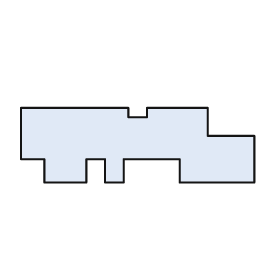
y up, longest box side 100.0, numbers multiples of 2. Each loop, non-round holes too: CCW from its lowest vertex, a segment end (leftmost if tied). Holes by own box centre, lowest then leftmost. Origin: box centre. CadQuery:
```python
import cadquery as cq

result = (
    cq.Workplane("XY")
    .moveTo(-40.0, -16.0)
    .lineTo(-22.0, -16.0)
    .lineTo(-22.0, -6.0)
    .lineTo(-14.0, -6.0)
    .lineTo(-14.0, -16.0)
    .lineTo(-6.0, -16.0)
    .lineTo(-6.0, -6.0)
    .lineTo(18.0, -6.0)
    .lineTo(18.0, -16.0)
    .lineTo(50.0, -16.0)
    .lineTo(50.0, 4.0)
    .lineTo(30.0, 4.0)
    .lineTo(30.0, 16.0)
    .lineTo(4.0, 16.0)
    .lineTo(4.0, 12.0)
    .lineTo(-4.0, 12.0)
    .lineTo(-4.0, 16.0)
    .lineTo(-50.0, 16.0)
    .lineTo(-50.0, -6.0)
    .lineTo(-40.0, -6.0)
    .close()
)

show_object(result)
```